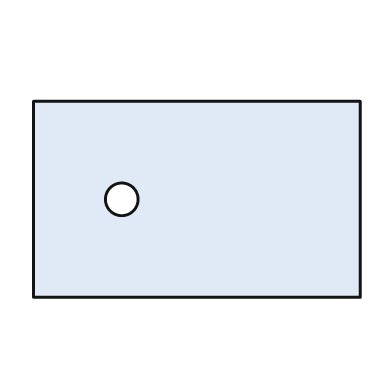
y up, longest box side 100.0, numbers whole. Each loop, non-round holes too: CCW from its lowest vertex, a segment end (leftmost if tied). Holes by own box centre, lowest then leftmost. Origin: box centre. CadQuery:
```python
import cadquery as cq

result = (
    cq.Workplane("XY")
    .moveTo(-50.0, -30.0)
    .lineTo(50.0, -30.0)
    .lineTo(50.0, 30.0)
    .lineTo(-50.0, 30.0)
    .close()
    .moveTo(-23.0, 0.0)
    .circle(5.0)
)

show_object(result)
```